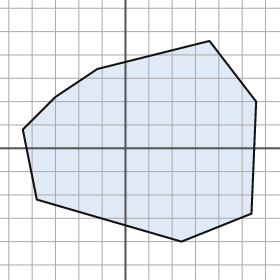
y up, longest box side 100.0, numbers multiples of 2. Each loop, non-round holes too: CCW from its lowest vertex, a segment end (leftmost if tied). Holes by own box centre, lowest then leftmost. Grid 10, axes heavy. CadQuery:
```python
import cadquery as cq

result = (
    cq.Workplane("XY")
    .moveTo(24.0, -40.0)
    .lineTo(54.0, -28.0)
    .lineTo(56.0, 20.0)
    .lineTo(36.0, 46.0)
    .lineTo(-12.0, 34.0)
    .lineTo(-30.0, 22.0)
    .lineTo(-44.0, 8.0)
    .lineTo(-38.0, -22.0)
    .close()
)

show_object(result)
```